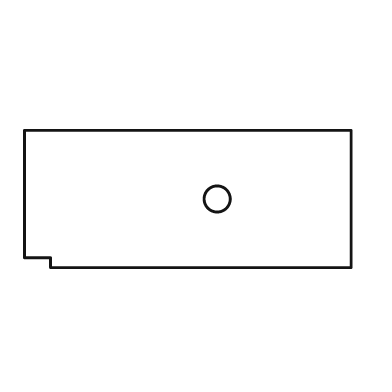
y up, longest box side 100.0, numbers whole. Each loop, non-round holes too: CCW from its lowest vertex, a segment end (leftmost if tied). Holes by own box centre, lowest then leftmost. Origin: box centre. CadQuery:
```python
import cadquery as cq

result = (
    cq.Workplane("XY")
    .moveTo(-42.0, -21.0)
    .lineTo(50.0, -21.0)
    .lineTo(50.0, 21.0)
    .lineTo(-50.0, 21.0)
    .lineTo(-50.0, -18.0)
    .lineTo(-42.0, -18.0)
    .close()
    .moveTo(9.0, 0.0)
    .circle(4.0)
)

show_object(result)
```